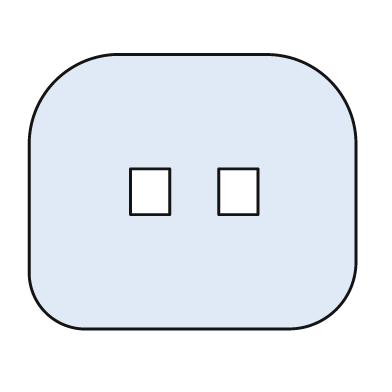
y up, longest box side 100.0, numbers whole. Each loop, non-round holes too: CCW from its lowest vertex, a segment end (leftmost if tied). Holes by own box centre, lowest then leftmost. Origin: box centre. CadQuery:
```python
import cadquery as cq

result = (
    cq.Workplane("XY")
    .moveTo(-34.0, -42.0)
    .lineTo(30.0, -42.0)
    .threePointArc((44.0, -36.0), (50.0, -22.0))
    .lineTo(50.0, 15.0)
    .threePointArc((42.0, 34.0), (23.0, 42.0))
    .lineTo(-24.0, 42.0)
    .threePointArc((-42.0, 34.0), (-50.0, 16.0))
    .lineTo(-50.0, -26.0)
    .threePointArc((-45.0, -37.0), (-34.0, -42.0))
    .close()
    .moveTo(-19.0, -7.0)
    .lineTo(-7.0, -7.0)
    .lineTo(-7.0, 7.0)
    .lineTo(-19.0, 7.0)
    .close()
    .moveTo(8.0, -7.0)
    .lineTo(20.0, -7.0)
    .lineTo(20.0, 7.0)
    .lineTo(8.0, 7.0)
    .close()
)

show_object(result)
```